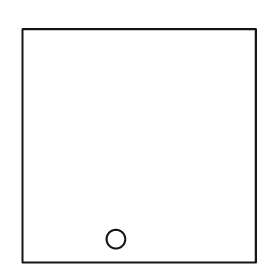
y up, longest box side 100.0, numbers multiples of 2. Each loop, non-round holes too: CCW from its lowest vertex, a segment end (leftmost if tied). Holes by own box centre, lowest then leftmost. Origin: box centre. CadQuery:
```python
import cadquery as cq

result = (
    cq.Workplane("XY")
    .moveTo(-50.0, -50.0)
    .lineTo(50.0, -50.0)
    .lineTo(50.0, 50.0)
    .lineTo(-50.0, 50.0)
    .close()
    .moveTo(-10.0, -40.0)
    .circle(4.0)
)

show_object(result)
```